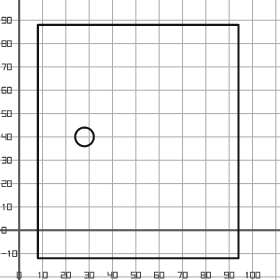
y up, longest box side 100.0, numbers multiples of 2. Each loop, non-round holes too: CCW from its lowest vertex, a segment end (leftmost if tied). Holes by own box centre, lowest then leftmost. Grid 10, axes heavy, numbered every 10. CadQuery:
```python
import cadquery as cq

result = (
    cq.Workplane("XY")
    .moveTo(8.0, -12.0)
    .lineTo(94.0, -12.0)
    .lineTo(94.0, 88.0)
    .lineTo(8.0, 88.0)
    .close()
    .moveTo(28.0, 40.0)
    .circle(4.0)
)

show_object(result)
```